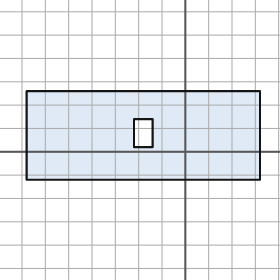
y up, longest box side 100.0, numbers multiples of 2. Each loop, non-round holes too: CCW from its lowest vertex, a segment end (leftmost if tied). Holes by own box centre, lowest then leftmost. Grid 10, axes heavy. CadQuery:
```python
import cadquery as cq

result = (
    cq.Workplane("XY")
    .moveTo(-68.0, -12.0)
    .lineTo(32.0, -12.0)
    .lineTo(32.0, 26.0)
    .lineTo(-68.0, 26.0)
    .close()
    .moveTo(-22.0, 2.0)
    .lineTo(-14.0, 2.0)
    .lineTo(-14.0, 14.0)
    .lineTo(-22.0, 14.0)
    .close()
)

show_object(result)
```